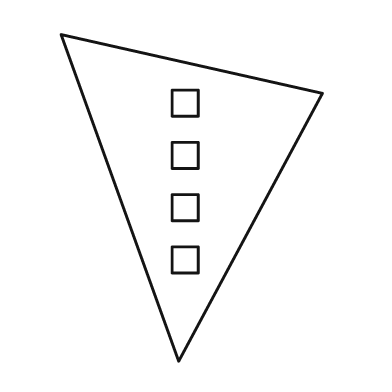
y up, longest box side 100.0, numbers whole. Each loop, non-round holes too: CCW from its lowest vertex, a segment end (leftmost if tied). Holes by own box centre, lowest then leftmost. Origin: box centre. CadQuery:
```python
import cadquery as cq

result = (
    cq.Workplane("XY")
    .moveTo(-4.0, -50.0)
    .lineTo(40.0, 32.0)
    .lineTo(-40.0, 50.0)
    .close()
    .moveTo(-6.0, -23.0)
    .lineTo(2.0, -23.0)
    .lineTo(2.0, -15.0)
    .lineTo(-6.0, -15.0)
    .close()
    .moveTo(-6.0, -7.0)
    .lineTo(2.0, -7.0)
    .lineTo(2.0, 1.0)
    .lineTo(-6.0, 1.0)
    .close()
    .moveTo(-6.0, 9.0)
    .lineTo(2.0, 9.0)
    .lineTo(2.0, 17.0)
    .lineTo(-6.0, 17.0)
    .close()
    .moveTo(-6.0, 25.0)
    .lineTo(2.0, 25.0)
    .lineTo(2.0, 33.0)
    .lineTo(-6.0, 33.0)
    .close()
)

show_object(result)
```